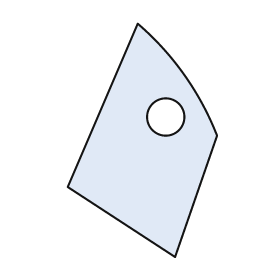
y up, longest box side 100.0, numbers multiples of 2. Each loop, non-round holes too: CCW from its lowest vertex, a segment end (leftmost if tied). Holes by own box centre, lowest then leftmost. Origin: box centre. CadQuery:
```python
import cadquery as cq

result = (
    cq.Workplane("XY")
    .moveTo(14.0, -50.0)
    .lineTo(32.0, 2.0)
    .threePointArc((18.0, 28.0), (-2.0, 50.0))
    .lineTo(-32.0, -20.0)
    .close()
    .moveTo(10.0, 10.0)
    .circle(8.0)
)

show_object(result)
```